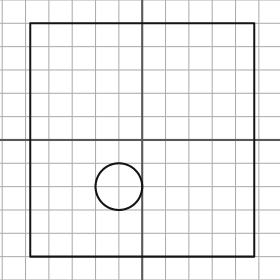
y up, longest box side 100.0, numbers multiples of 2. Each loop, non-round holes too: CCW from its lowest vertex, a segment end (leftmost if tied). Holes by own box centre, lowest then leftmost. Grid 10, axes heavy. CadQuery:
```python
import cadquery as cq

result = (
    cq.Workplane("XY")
    .moveTo(-48.0, -50.0)
    .lineTo(48.0, -50.0)
    .lineTo(48.0, 50.0)
    .lineTo(-48.0, 50.0)
    .close()
    .moveTo(-10.0, -20.0)
    .circle(10.0)
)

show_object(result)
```